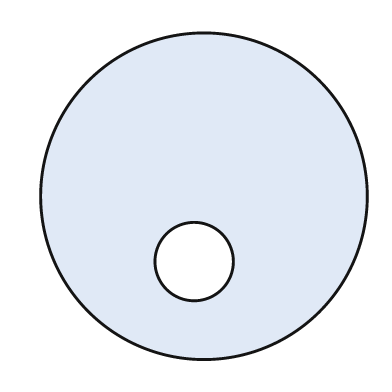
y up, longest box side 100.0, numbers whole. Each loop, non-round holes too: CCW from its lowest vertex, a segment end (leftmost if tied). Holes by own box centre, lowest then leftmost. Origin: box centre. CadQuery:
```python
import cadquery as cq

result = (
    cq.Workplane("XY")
    .moveTo(0.0, 0.0)
    .circle(50.0)
    .moveTo(-3.0, -20.0)
    .circle(12.0)
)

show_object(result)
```